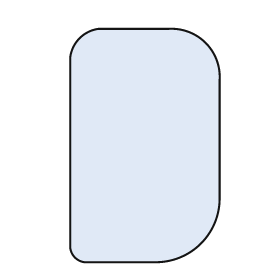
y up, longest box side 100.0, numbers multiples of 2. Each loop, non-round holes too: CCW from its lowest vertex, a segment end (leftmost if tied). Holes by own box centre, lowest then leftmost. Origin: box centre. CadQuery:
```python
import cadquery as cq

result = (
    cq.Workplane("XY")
    .moveTo(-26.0, -50.0)
    .lineTo(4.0, -50.0)
    .threePointArc((24.0, -42.0), (32.0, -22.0))
    .lineTo(32.0, 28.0)
    .threePointArc((26.0, 44.0), (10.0, 50.0))
    .lineTo(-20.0, 50.0)
    .threePointArc((-28.0, 46.0), (-32.0, 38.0))
    .lineTo(-32.0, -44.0)
    .threePointArc((-30.0, -48.0), (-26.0, -50.0))
    .close()
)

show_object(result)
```